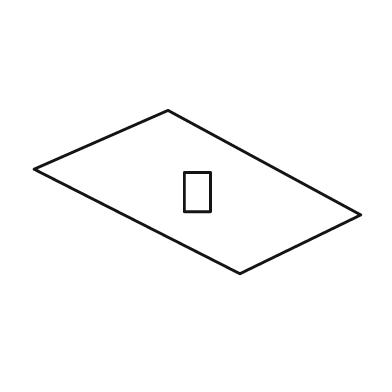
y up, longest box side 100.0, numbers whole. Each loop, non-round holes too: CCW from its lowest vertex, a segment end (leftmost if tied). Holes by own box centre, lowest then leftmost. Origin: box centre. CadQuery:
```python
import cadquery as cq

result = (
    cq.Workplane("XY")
    .moveTo(13.0, -25.0)
    .lineTo(50.0, -7.0)
    .lineTo(-9.0, 25.0)
    .lineTo(-50.0, 7.0)
    .close()
    .moveTo(-4.0, -6.0)
    .lineTo(4.0, -6.0)
    .lineTo(4.0, 6.0)
    .lineTo(-4.0, 6.0)
    .close()
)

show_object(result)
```